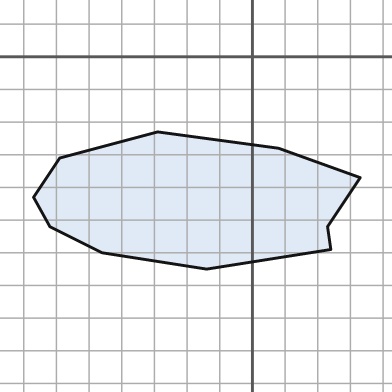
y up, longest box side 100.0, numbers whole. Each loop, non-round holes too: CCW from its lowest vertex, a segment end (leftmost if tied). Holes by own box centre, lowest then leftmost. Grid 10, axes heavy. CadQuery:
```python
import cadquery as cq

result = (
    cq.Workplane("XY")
    .moveTo(-14.0, -65.0)
    .lineTo(24.0, -59.0)
    .lineTo(23.0, -52.0)
    .lineTo(33.0, -37.0)
    .lineTo(8.0, -28.0)
    .lineTo(-29.0, -23.0)
    .lineTo(-59.0, -31.0)
    .lineTo(-67.0, -43.0)
    .lineTo(-62.0, -52.0)
    .lineTo(-46.0, -60.0)
    .close()
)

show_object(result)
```